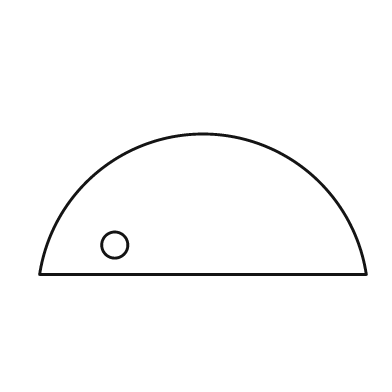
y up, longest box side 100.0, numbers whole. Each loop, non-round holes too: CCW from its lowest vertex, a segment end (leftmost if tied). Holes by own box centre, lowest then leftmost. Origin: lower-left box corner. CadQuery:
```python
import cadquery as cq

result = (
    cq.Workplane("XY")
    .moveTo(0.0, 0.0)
    .lineTo(100.0, 0.0)
    .threePointArc((50.0, 43.0), (0.0, 0.0))
    .close()
    .moveTo(23.0, 9.0)
    .circle(4.0)
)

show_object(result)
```